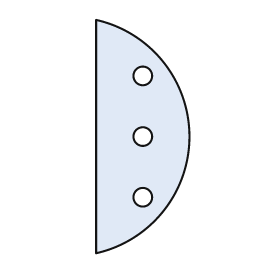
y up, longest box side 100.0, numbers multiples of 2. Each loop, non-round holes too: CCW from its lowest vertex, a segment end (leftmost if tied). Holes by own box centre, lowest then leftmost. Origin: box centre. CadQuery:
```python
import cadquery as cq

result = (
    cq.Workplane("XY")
    .moveTo(-20.0, -50.0)
    .threePointArc((20.0, 0.0), (-20.0, 50.0))
    .close()
    .moveTo(0.0, -26.0)
    .circle(4.0)
    .moveTo(0.0, 0.0)
    .circle(4.0)
    .moveTo(0.0, 26.0)
    .circle(4.0)
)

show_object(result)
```